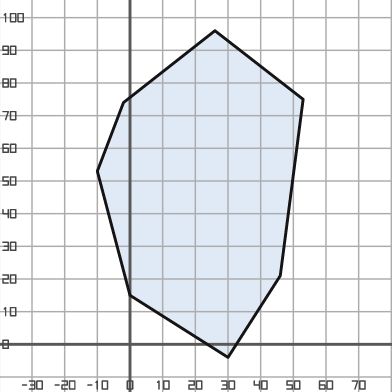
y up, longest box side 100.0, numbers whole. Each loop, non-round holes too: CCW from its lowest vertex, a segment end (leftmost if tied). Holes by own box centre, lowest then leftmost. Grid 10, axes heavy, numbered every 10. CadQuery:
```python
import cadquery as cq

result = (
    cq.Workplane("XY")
    .moveTo(30.0, -4.0)
    .lineTo(46.0, 21.0)
    .lineTo(53.0, 75.0)
    .lineTo(26.0, 96.0)
    .lineTo(-2.0, 74.0)
    .lineTo(-10.0, 53.0)
    .lineTo(0.0, 15.0)
    .close()
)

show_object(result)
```